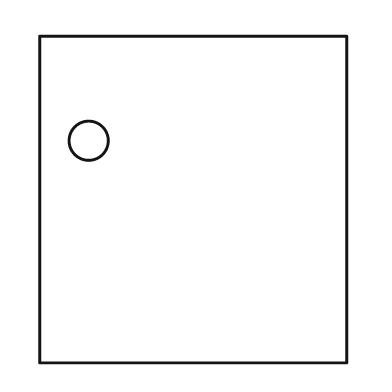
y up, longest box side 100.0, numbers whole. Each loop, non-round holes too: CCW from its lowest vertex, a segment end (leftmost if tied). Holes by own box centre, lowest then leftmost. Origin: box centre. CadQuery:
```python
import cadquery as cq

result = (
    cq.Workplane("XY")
    .moveTo(-47.0, -50.0)
    .lineTo(47.0, -50.0)
    .lineTo(47.0, 50.0)
    .lineTo(-47.0, 50.0)
    .close()
    .moveTo(-32.0, 18.0)
    .circle(6.0)
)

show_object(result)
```